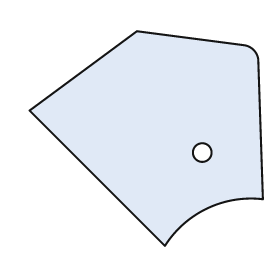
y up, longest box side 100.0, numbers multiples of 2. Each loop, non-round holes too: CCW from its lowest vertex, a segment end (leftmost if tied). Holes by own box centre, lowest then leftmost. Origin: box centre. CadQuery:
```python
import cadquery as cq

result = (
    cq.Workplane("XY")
    .moveTo(8.0, -46.0)
    .threePointArc((26.0, -30.0), (50.0, -26.0))
    .lineTo(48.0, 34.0)
    .threePointArc((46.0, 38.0), (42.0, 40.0))
    .lineTo(-4.0, 46.0)
    .lineTo(-50.0, 12.0)
    .close()
    .moveTo(24.0, -6.0)
    .circle(4.0)
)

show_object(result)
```